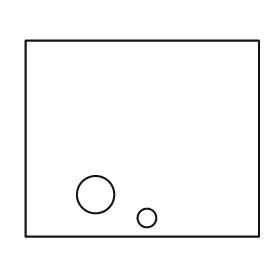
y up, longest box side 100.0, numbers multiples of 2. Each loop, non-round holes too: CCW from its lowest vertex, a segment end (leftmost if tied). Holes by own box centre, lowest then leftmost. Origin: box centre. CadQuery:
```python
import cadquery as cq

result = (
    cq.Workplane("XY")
    .moveTo(-50.0, -42.0)
    .lineTo(50.0, -42.0)
    .lineTo(50.0, 42.0)
    .lineTo(-50.0, 42.0)
    .close()
    .moveTo(2.0, -34.0)
    .circle(4.0)
    .moveTo(-20.0, -24.0)
    .circle(8.0)
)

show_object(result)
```